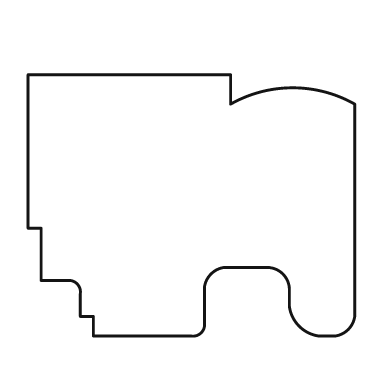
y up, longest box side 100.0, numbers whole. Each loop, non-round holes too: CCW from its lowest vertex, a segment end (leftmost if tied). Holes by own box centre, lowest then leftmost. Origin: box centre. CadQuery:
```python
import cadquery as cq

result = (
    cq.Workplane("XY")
    .moveTo(-30.0, -40.0)
    .lineTo(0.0, -40.0)
    .threePointArc((3.0, -39.0), (4.0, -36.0))
    .lineTo(4.0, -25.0)
    .threePointArc((6.0, -21.0), (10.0, -19.0))
    .lineTo(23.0, -19.0)
    .threePointArc((28.0, -21.0), (30.0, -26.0))
    .lineTo(30.0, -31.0)
    .threePointArc((33.0, -37.0), (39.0, -40.0))
    .lineTo(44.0, -40.0)
    .threePointArc((48.0, -38.0), (50.0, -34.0))
    .lineTo(50.0, 31.0)
    .threePointArc((31.0, 36.0), (12.0, 31.0))
    .lineTo(12.0, 40.0)
    .lineTo(-50.0, 40.0)
    .lineTo(-50.0, -7.0)
    .lineTo(-46.0, -7.0)
    .lineTo(-46.0, -23.0)
    .lineTo(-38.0, -23.0)
    .threePointArc((-35.0, -24.0), (-34.0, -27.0))
    .lineTo(-34.0, -34.0)
    .lineTo(-30.0, -34.0)
    .close()
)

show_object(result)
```